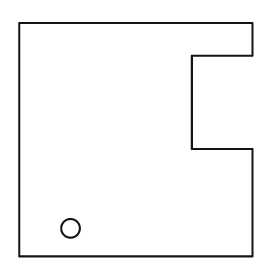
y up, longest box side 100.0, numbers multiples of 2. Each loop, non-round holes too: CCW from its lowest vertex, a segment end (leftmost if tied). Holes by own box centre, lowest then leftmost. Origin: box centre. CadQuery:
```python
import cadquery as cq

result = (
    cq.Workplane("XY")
    .moveTo(-50.0, -50.0)
    .lineTo(50.0, -50.0)
    .lineTo(50.0, -4.0)
    .lineTo(24.0, -4.0)
    .lineTo(24.0, 36.0)
    .lineTo(50.0, 36.0)
    .lineTo(50.0, 50.0)
    .lineTo(-50.0, 50.0)
    .close()
    .moveTo(-28.0, -38.0)
    .circle(4.0)
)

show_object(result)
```